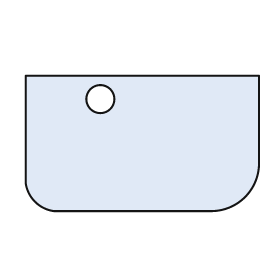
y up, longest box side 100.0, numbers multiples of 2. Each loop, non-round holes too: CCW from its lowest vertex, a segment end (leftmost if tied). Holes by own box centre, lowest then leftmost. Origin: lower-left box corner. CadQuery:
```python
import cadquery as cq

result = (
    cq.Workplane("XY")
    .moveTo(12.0, 0.0)
    .lineTo(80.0, 0.0)
    .threePointArc((94.0, 6.0), (100.0, 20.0))
    .lineTo(100.0, 58.0)
    .lineTo(0.0, 58.0)
    .lineTo(0.0, 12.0)
    .threePointArc((4.0, 4.0), (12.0, 0.0))
    .close()
    .moveTo(32.0, 48.0)
    .circle(6.0)
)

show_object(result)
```